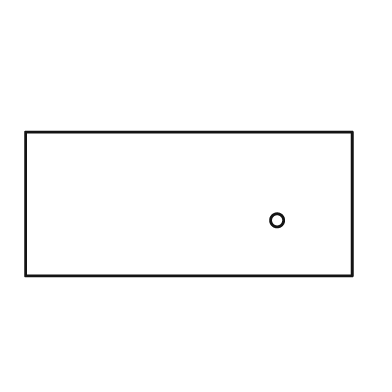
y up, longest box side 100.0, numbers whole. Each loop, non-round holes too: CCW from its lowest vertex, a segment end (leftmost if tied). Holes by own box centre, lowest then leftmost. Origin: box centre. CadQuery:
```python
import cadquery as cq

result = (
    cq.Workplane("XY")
    .moveTo(-50.0, -22.0)
    .lineTo(50.0, -22.0)
    .lineTo(50.0, 22.0)
    .lineTo(-50.0, 22.0)
    .close()
    .moveTo(27.0, -5.0)
    .circle(2.0)
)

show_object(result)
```